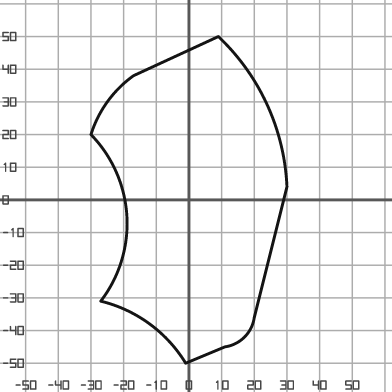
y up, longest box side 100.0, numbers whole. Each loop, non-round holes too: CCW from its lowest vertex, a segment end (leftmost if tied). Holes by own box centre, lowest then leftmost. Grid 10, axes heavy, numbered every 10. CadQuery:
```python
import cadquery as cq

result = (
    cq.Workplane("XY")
    .moveTo(-1.0, -50.0)
    .lineTo(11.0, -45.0)
    .threePointArc((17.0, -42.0), (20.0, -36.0))
    .lineTo(30.0, 4.0)
    .threePointArc((24.0, 29.0), (9.0, 50.0))
    .lineTo(-17.0, 38.0)
    .threePointArc((-25.0, 30.0), (-30.0, 20.0))
    .threePointArc((-19.0, -5.0), (-27.0, -31.0))
    .threePointArc((-12.0, -38.0), (-1.0, -50.0))
    .close()
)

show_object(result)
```